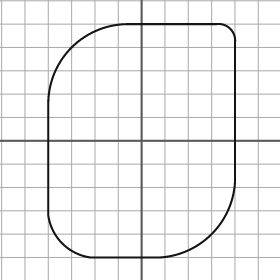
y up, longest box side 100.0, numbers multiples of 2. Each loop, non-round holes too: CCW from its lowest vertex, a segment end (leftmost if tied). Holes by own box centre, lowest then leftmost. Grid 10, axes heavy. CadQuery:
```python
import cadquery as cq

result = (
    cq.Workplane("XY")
    .moveTo(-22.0, -50.0)
    .lineTo(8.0, -50.0)
    .threePointArc((30.0, -40.0), (40.0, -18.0))
    .lineTo(40.0, 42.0)
    .threePointArc((38.0, 48.0), (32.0, 50.0))
    .lineTo(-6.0, 50.0)
    .threePointArc((-30.0, 40.0), (-40.0, 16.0))
    .lineTo(-40.0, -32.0)
    .threePointArc((-34.0, -44.0), (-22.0, -50.0))
    .close()
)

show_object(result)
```